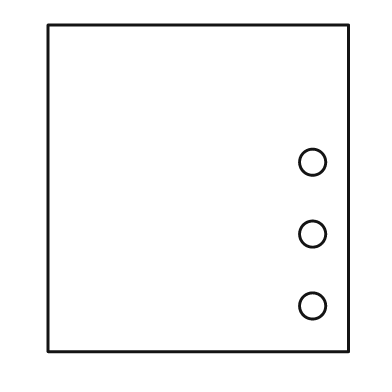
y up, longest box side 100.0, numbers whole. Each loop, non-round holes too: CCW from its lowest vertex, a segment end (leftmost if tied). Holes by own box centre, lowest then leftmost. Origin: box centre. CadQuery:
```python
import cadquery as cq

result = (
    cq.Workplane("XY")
    .moveTo(-46.0, -50.0)
    .lineTo(46.0, -50.0)
    .lineTo(46.0, 50.0)
    .lineTo(-46.0, 50.0)
    .close()
    .moveTo(35.0, -36.0)
    .circle(4.0)
    .moveTo(35.0, -14.0)
    .circle(4.0)
    .moveTo(35.0, 8.0)
    .circle(4.0)
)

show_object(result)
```